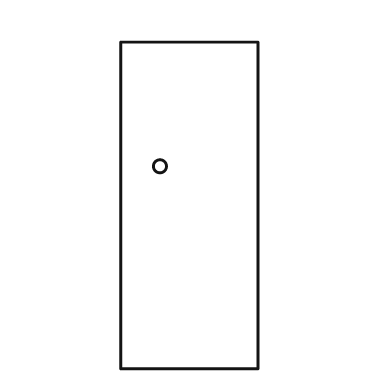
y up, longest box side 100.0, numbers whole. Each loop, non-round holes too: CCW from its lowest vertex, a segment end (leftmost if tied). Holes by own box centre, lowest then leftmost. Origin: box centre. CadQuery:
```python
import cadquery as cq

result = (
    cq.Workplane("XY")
    .moveTo(-21.0, -50.0)
    .lineTo(21.0, -50.0)
    .lineTo(21.0, 50.0)
    .lineTo(-21.0, 50.0)
    .close()
    .moveTo(-9.0, 12.0)
    .circle(2.0)
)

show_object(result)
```